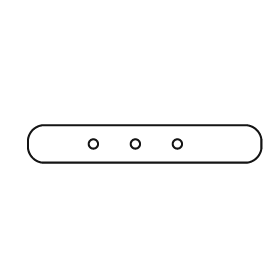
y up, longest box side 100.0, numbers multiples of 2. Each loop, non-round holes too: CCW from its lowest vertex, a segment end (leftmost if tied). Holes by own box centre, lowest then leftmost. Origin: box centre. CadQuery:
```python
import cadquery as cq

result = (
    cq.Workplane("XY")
    .moveTo(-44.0, -8.0)
    .lineTo(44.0, -8.0)
    .threePointArc((48.0, -6.0), (50.0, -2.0))
    .lineTo(50.0, 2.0)
    .threePointArc((48.0, 6.0), (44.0, 8.0))
    .lineTo(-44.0, 8.0)
    .threePointArc((-48.0, 6.0), (-50.0, 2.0))
    .lineTo(-50.0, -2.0)
    .threePointArc((-48.0, -6.0), (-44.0, -8.0))
    .close()
    .moveTo(-22.0, 0.0)
    .circle(2.0)
    .moveTo(-4.0, 0.0)
    .circle(2.0)
    .moveTo(14.0, 0.0)
    .circle(2.0)
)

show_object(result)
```